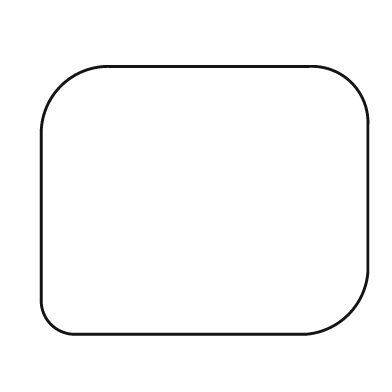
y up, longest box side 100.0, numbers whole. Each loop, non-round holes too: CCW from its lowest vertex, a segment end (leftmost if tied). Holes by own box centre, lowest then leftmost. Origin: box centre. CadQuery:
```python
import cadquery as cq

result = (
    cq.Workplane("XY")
    .moveTo(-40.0, -41.0)
    .lineTo(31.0, -41.0)
    .threePointArc((44.0, -35.0), (50.0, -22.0))
    .lineTo(50.0, 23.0)
    .threePointArc((45.0, 36.0), (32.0, 41.0))
    .lineTo(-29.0, 41.0)
    .threePointArc((-44.0, 35.0), (-50.0, 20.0))
    .lineTo(-50.0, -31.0)
    .threePointArc((-47.0, -38.0), (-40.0, -41.0))
    .close()
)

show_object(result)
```